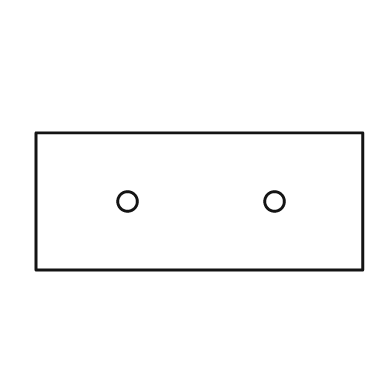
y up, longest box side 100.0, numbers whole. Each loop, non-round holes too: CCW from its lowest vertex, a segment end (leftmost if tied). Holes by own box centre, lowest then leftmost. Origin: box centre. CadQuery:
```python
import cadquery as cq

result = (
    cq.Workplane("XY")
    .moveTo(-50.0, -21.0)
    .lineTo(50.0, -21.0)
    .lineTo(50.0, 21.0)
    .lineTo(-50.0, 21.0)
    .close()
    .moveTo(-22.0, 0.0)
    .circle(3.0)
    .moveTo(23.0, 0.0)
    .circle(3.0)
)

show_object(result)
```